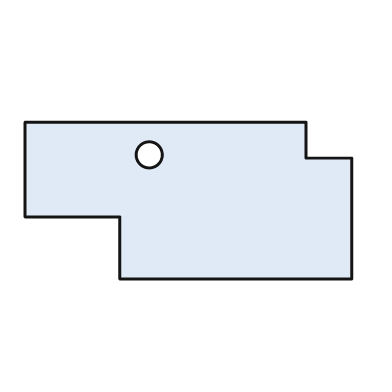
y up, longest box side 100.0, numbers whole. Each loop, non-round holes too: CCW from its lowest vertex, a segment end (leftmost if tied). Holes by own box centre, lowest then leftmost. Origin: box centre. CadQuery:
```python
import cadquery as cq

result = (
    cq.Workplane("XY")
    .moveTo(-21.0, -24.0)
    .lineTo(50.0, -24.0)
    .lineTo(50.0, 13.0)
    .lineTo(36.0, 13.0)
    .lineTo(36.0, 24.0)
    .lineTo(-50.0, 24.0)
    .lineTo(-50.0, -5.0)
    .lineTo(-21.0, -5.0)
    .close()
    .moveTo(-12.0, 14.0)
    .circle(4.0)
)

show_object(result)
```